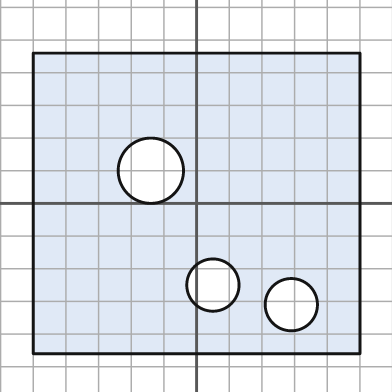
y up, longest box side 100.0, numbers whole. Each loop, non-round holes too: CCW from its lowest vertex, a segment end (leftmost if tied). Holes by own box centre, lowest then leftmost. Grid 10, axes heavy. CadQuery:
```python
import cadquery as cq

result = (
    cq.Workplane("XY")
    .moveTo(-50.0, -46.0)
    .lineTo(50.0, -46.0)
    .lineTo(50.0, 46.0)
    .lineTo(-50.0, 46.0)
    .close()
    .moveTo(29.0, -31.0)
    .circle(8.0)
    .moveTo(5.0, -25.0)
    .circle(8.0)
    .moveTo(-14.0, 10.0)
    .circle(10.0)
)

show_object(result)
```